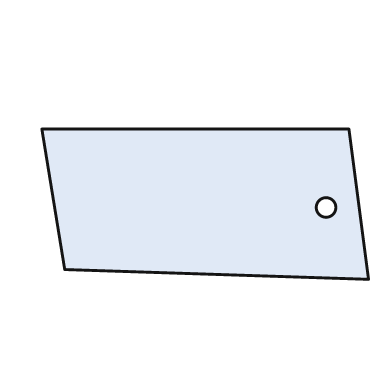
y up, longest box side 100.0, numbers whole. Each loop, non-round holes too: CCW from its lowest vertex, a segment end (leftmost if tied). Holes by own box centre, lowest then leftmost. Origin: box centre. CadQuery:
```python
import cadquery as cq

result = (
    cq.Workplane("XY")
    .moveTo(50.0, -23.0)
    .lineTo(44.0, 23.0)
    .lineTo(-50.0, 23.0)
    .lineTo(-43.0, -20.0)
    .close()
    .moveTo(37.0, -1.0)
    .circle(3.0)
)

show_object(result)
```